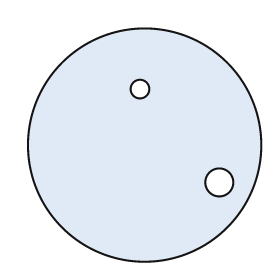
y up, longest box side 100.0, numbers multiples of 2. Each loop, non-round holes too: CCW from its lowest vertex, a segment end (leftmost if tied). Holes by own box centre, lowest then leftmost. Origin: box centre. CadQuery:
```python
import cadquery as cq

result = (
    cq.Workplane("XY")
    .moveTo(0.0, 0.0)
    .circle(50.0)
    .moveTo(32.0, -16.0)
    .circle(6.0)
    .moveTo(-2.0, 24.0)
    .circle(4.0)
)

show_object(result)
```